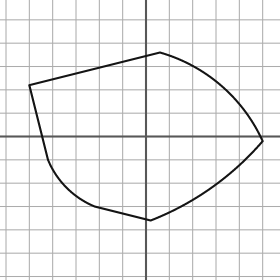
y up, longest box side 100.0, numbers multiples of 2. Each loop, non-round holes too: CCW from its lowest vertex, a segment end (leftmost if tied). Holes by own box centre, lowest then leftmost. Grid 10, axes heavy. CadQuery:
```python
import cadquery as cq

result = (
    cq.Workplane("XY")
    .moveTo(2.0, -36.0)
    .threePointArc((28.0, -22.0), (50.0, -2.0))
    .threePointArc((32.0, 22.0), (6.0, 36.0))
    .lineTo(-50.0, 22.0)
    .lineTo(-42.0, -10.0)
    .threePointArc((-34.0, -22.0), (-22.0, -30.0))
    .close()
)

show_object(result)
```